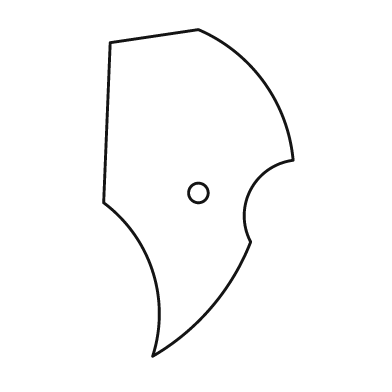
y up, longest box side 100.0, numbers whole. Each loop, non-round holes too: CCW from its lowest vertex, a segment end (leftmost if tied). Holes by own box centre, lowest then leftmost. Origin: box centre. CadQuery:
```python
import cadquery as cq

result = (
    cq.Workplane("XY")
    .moveTo(-14.0, -50.0)
    .threePointArc((4.0, -35.0), (16.0, -15.0))
    .threePointArc((16.0, 1.0), (29.0, 10.0))
    .threePointArc((20.0, 34.0), (0.0, 50.0))
    .lineTo(-27.0, 46.0)
    .lineTo(-29.0, -3.0)
    .threePointArc((-14.0, -24.0), (-14.0, -50.0))
    .close()
    .moveTo(0.0, 0.0)
    .circle(3.0)
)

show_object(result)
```